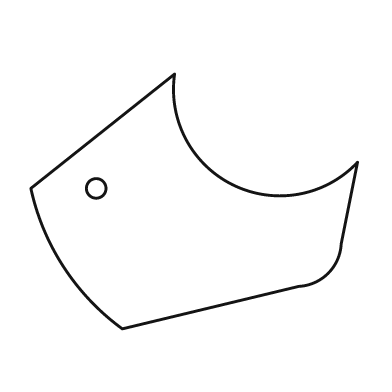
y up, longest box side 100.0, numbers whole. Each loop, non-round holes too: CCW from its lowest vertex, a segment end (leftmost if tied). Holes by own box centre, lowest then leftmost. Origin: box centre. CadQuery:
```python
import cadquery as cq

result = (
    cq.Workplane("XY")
    .moveTo(-22.0, -39.0)
    .lineTo(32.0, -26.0)
    .threePointArc((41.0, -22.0), (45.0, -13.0))
    .lineTo(50.0, 12.0)
    .threePointArc((12.0, 5.0), (-6.0, 39.0))
    .lineTo(-50.0, 4.0)
    .threePointArc((-40.0, -20.0), (-22.0, -39.0))
    .close()
    .moveTo(-30.0, 4.0)
    .circle(3.0)
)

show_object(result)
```